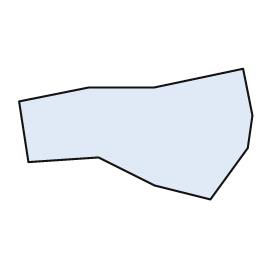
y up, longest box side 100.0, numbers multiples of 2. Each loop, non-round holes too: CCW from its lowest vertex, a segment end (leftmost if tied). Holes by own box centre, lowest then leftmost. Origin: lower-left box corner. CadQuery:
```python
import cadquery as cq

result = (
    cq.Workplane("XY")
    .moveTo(82.0, 0.0)
    .lineTo(98.0, 22.0)
    .lineTo(100.0, 36.0)
    .lineTo(96.0, 56.0)
    .lineTo(58.0, 48.0)
    .lineTo(30.0, 48.0)
    .lineTo(0.0, 42.0)
    .lineTo(4.0, 16.0)
    .lineTo(34.0, 18.0)
    .lineTo(58.0, 6.0)
    .close()
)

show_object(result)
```